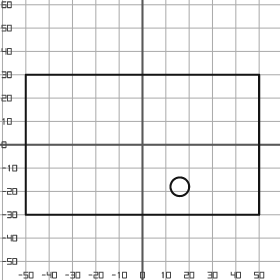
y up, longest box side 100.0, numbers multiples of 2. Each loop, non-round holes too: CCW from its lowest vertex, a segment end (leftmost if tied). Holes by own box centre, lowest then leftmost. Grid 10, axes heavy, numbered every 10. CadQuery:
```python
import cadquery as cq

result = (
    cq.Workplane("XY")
    .moveTo(-50.0, -30.0)
    .lineTo(50.0, -30.0)
    .lineTo(50.0, 30.0)
    .lineTo(-50.0, 30.0)
    .close()
    .moveTo(16.0, -18.0)
    .circle(4.0)
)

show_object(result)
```